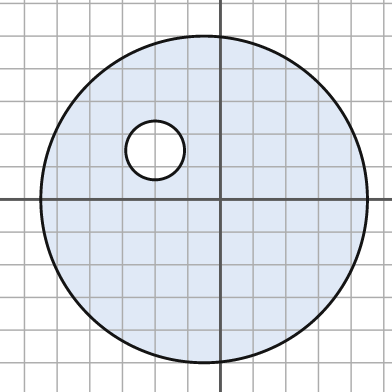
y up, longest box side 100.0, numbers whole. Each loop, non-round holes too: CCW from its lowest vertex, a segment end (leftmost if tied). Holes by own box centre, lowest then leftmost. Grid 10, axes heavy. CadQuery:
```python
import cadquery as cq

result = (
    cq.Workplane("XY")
    .moveTo(-5.0, 0.0)
    .circle(50.0)
    .moveTo(-20.0, 15.0)
    .circle(9.0)
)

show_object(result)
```